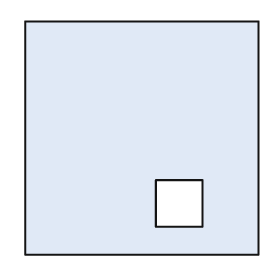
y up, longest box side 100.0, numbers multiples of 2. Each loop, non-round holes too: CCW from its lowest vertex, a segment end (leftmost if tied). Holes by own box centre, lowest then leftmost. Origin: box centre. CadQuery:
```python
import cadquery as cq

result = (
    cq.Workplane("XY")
    .moveTo(-50.0, -50.0)
    .lineTo(50.0, -50.0)
    .lineTo(50.0, 50.0)
    .lineTo(-50.0, 50.0)
    .close()
    .moveTo(6.0, -38.0)
    .lineTo(26.0, -38.0)
    .lineTo(26.0, -18.0)
    .lineTo(6.0, -18.0)
    .close()
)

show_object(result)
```